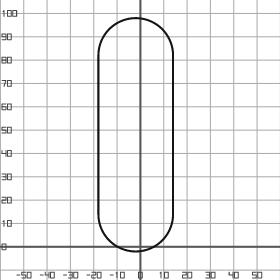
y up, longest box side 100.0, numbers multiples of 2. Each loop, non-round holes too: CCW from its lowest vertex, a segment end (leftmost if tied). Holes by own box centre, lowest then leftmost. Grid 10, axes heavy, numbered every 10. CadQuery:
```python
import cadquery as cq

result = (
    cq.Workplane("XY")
    .moveTo(-18.0, 14.0)
    .threePointArc((-2.0, -2.0), (14.0, 14.0))
    .lineTo(14.0, 82.0)
    .threePointArc((-2.0, 98.0), (-18.0, 82.0))
    .close()
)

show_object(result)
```